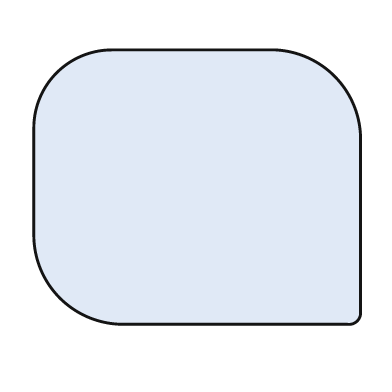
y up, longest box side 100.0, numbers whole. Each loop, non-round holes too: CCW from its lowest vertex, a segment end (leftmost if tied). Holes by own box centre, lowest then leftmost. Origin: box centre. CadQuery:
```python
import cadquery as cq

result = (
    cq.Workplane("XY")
    .moveTo(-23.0, -42.0)
    .lineTo(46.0, -42.0)
    .threePointArc((49.0, -41.0), (50.0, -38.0))
    .lineTo(50.0, 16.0)
    .threePointArc((42.0, 34.0), (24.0, 42.0))
    .lineTo(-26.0, 42.0)
    .threePointArc((-43.0, 35.0), (-50.0, 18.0))
    .lineTo(-50.0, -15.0)
    .threePointArc((-42.0, -34.0), (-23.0, -42.0))
    .close()
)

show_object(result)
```